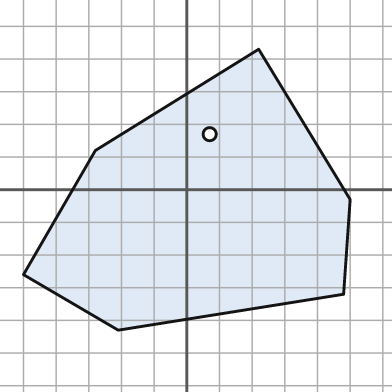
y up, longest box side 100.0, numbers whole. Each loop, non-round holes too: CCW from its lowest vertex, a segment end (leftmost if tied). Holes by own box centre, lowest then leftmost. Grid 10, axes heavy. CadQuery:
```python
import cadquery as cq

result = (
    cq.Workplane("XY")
    .moveTo(-21.0, -43.0)
    .lineTo(48.0, -32.0)
    .lineTo(50.0, -3.0)
    .lineTo(22.0, 43.0)
    .lineTo(-28.0, 12.0)
    .lineTo(-50.0, -26.0)
    .close()
    .moveTo(7.0, 17.0)
    .circle(2.0)
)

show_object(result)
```